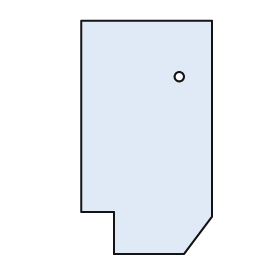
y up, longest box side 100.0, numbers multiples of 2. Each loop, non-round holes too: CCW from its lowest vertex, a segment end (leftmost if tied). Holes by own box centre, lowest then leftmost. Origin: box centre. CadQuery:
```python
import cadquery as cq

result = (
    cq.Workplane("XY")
    .moveTo(-14.0, -50.0)
    .lineTo(16.0, -50.0)
    .lineTo(28.0, -34.0)
    .lineTo(28.0, 50.0)
    .lineTo(-28.0, 50.0)
    .lineTo(-28.0, -32.0)
    .lineTo(-14.0, -32.0)
    .close()
    .moveTo(14.0, 26.0)
    .circle(2.0)
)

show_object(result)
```